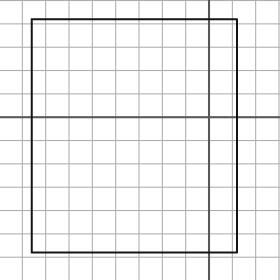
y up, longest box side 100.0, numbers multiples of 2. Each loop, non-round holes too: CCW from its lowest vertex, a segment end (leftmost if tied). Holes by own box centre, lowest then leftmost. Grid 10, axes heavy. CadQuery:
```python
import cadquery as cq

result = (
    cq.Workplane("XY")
    .moveTo(-76.0, -58.0)
    .lineTo(12.0, -58.0)
    .lineTo(12.0, 42.0)
    .lineTo(-76.0, 42.0)
    .close()
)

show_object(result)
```